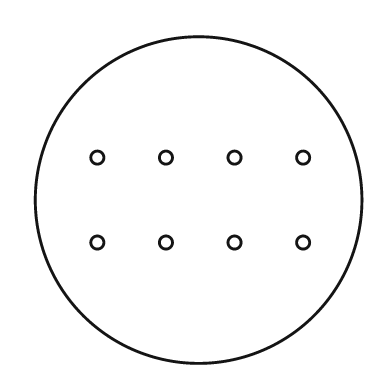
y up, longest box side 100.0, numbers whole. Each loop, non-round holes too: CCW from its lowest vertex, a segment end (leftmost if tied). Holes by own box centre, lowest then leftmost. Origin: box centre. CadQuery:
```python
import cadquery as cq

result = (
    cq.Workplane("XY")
    .moveTo(0.0, 0.0)
    .circle(50.0)
    .moveTo(-31.0, -13.0)
    .circle(2.0)
    .moveTo(-10.0, -13.0)
    .circle(2.0)
    .moveTo(11.0, -13.0)
    .circle(2.0)
    .moveTo(32.0, -13.0)
    .circle(2.0)
    .moveTo(-31.0, 13.0)
    .circle(2.0)
    .moveTo(-10.0, 13.0)
    .circle(2.0)
    .moveTo(11.0, 13.0)
    .circle(2.0)
    .moveTo(32.0, 13.0)
    .circle(2.0)
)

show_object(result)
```